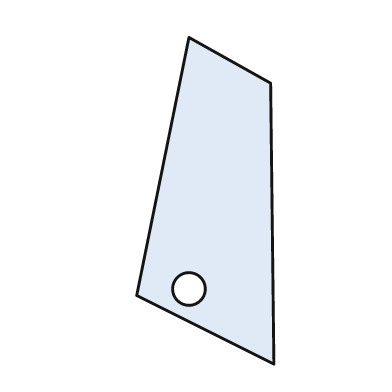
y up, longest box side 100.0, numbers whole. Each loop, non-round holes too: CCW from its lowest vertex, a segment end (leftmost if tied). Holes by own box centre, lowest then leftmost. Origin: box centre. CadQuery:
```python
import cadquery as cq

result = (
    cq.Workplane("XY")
    .moveTo(21.0, -50.0)
    .lineTo(20.0, 36.0)
    .lineTo(-5.0, 50.0)
    .lineTo(-21.0, -29.0)
    .close()
    .moveTo(-5.0, -27.0)
    .circle(5.0)
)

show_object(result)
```